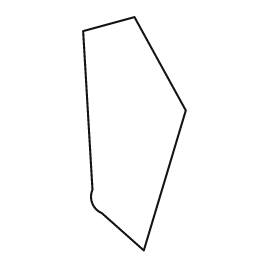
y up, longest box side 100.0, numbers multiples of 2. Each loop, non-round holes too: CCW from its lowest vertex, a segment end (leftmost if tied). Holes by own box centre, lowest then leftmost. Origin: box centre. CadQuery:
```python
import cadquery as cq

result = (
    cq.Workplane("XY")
    .moveTo(4.0, -50.0)
    .lineTo(22.0, 10.0)
    .lineTo(0.0, 50.0)
    .lineTo(-22.0, 44.0)
    .lineTo(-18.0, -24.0)
    .threePointArc((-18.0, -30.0), (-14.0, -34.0))
    .close()
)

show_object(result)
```